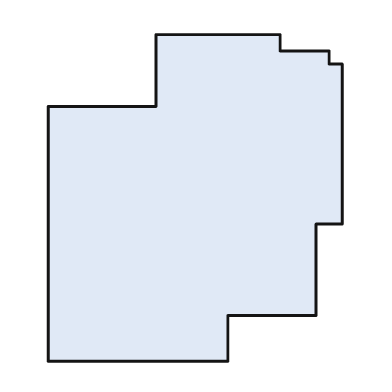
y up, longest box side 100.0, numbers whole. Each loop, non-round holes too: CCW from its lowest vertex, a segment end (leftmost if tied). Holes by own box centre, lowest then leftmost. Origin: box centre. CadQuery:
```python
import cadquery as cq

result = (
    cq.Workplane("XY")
    .moveTo(-45.0, -50.0)
    .lineTo(10.0, -50.0)
    .lineTo(10.0, -36.0)
    .lineTo(37.0, -36.0)
    .lineTo(37.0, -8.0)
    .lineTo(45.0, -8.0)
    .lineTo(45.0, 41.0)
    .lineTo(41.0, 41.0)
    .lineTo(41.0, 45.0)
    .lineTo(26.0, 45.0)
    .lineTo(26.0, 50.0)
    .lineTo(-12.0, 50.0)
    .lineTo(-12.0, 28.0)
    .lineTo(-45.0, 28.0)
    .close()
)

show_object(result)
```